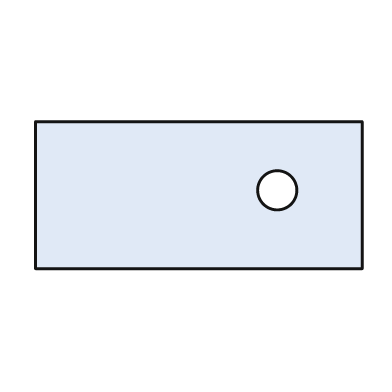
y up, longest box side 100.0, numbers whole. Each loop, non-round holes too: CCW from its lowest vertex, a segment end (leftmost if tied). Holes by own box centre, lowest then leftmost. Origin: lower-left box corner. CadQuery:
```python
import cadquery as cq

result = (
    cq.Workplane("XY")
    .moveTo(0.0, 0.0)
    .lineTo(100.0, 0.0)
    .lineTo(100.0, 45.0)
    .lineTo(0.0, 45.0)
    .close()
    .moveTo(74.0, 24.0)
    .circle(6.0)
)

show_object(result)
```